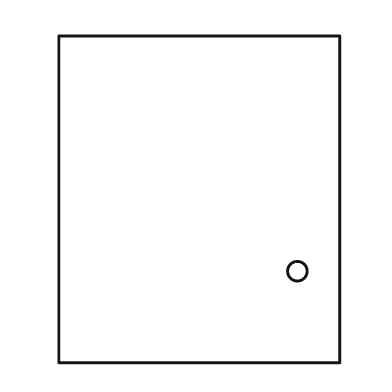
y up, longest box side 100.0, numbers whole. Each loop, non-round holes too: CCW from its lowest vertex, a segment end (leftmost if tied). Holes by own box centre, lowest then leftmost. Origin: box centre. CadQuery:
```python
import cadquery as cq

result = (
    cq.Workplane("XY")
    .moveTo(-43.0, -50.0)
    .lineTo(43.0, -50.0)
    .lineTo(43.0, 50.0)
    .lineTo(-43.0, 50.0)
    .close()
    .moveTo(30.0, -22.0)
    .circle(3.0)
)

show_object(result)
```